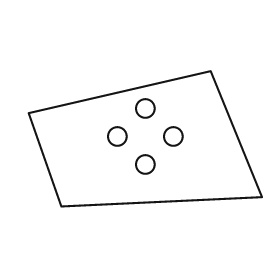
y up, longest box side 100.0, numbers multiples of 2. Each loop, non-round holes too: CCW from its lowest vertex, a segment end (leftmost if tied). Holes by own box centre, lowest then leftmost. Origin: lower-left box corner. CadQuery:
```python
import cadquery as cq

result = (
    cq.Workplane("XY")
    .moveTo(14.0, 0.0)
    .lineTo(100.0, 4.0)
    .lineTo(78.0, 58.0)
    .lineTo(0.0, 40.0)
    .close()
    .moveTo(50.0, 18.0)
    .circle(4.0)
    .moveTo(38.0, 30.0)
    .circle(4.0)
    .moveTo(62.0, 30.0)
    .circle(4.0)
    .moveTo(50.0, 42.0)
    .circle(4.0)
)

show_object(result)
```